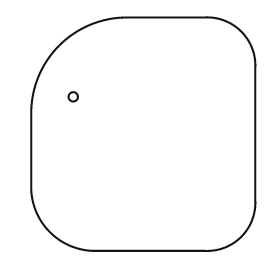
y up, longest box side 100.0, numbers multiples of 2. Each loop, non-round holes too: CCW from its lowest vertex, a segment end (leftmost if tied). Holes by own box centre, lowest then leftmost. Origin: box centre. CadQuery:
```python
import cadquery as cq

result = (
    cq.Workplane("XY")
    .moveTo(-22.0, -50.0)
    .lineTo(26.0, -50.0)
    .threePointArc((42.0, -44.0), (48.0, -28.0))
    .lineTo(48.0, 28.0)
    .threePointArc((42.0, 44.0), (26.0, 50.0))
    .lineTo(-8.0, 50.0)
    .threePointArc((-36.0, 38.0), (-48.0, 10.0))
    .lineTo(-48.0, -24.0)
    .threePointArc((-40.0, -42.0), (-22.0, -50.0))
    .close()
    .moveTo(-30.0, 16.0)
    .circle(2.0)
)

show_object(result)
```